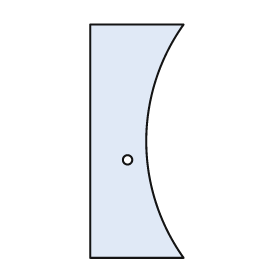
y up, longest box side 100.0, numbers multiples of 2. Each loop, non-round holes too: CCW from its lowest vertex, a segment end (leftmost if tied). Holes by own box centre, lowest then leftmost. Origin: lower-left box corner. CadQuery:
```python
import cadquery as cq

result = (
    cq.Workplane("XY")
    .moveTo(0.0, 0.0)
    .lineTo(40.0, 0.0)
    .threePointArc((24.0, 50.0), (40.0, 100.0))
    .lineTo(0.0, 100.0)
    .close()
    .moveTo(16.0, 42.0)
    .circle(2.0)
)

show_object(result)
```